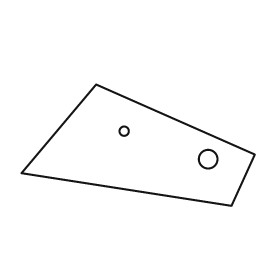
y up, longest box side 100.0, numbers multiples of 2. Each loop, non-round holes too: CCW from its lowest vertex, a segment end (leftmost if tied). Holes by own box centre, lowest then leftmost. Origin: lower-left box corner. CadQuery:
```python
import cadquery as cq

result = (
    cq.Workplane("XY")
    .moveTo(90.0, 0.0)
    .lineTo(100.0, 22.0)
    .lineTo(32.0, 52.0)
    .lineTo(0.0, 14.0)
    .close()
    .moveTo(80.0, 20.0)
    .circle(4.0)
    .moveTo(44.0, 32.0)
    .circle(2.0)
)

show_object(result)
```